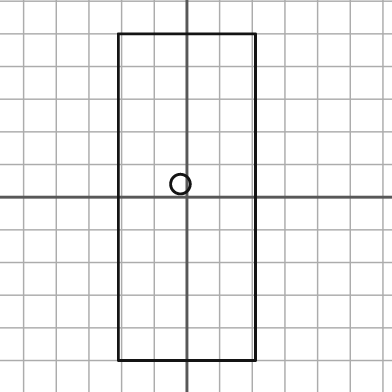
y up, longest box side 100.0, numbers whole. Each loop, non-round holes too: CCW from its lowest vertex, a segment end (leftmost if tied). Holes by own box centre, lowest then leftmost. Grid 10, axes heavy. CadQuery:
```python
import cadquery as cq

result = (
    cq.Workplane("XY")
    .moveTo(-21.0, -50.0)
    .lineTo(21.0, -50.0)
    .lineTo(21.0, 50.0)
    .lineTo(-21.0, 50.0)
    .close()
    .moveTo(-2.0, 4.0)
    .circle(3.0)
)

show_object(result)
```